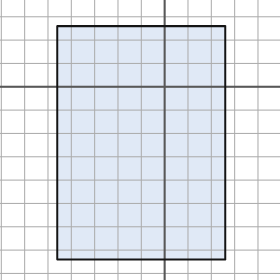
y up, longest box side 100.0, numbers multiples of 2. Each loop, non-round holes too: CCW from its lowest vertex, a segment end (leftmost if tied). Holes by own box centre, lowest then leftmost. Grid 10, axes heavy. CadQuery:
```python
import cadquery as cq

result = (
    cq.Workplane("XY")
    .moveTo(-46.0, -74.0)
    .lineTo(26.0, -74.0)
    .lineTo(26.0, 26.0)
    .lineTo(-46.0, 26.0)
    .close()
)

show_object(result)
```